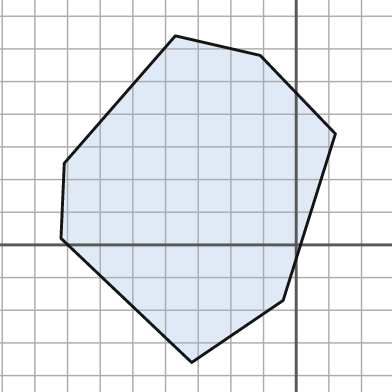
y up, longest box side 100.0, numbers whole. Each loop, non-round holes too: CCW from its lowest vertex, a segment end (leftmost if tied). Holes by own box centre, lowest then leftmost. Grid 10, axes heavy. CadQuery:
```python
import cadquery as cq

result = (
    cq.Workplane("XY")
    .moveTo(-32.0, -36.0)
    .lineTo(-4.0, -17.0)
    .lineTo(12.0, 34.0)
    .lineTo(-11.0, 58.0)
    .lineTo(-37.0, 64.0)
    .lineTo(-71.0, 25.0)
    .lineTo(-72.0, 2.0)
    .close()
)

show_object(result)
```